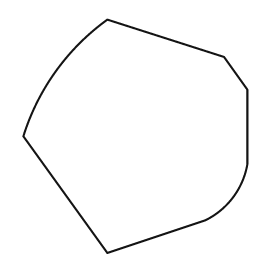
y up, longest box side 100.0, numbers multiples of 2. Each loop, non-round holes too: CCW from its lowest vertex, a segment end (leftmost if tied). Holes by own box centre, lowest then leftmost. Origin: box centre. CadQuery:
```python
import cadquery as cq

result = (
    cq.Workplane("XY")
    .moveTo(-12.0, -50.0)
    .lineTo(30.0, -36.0)
    .threePointArc((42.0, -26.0), (48.0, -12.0))
    .lineTo(48.0, 20.0)
    .lineTo(38.0, 34.0)
    .lineTo(-12.0, 50.0)
    .threePointArc((-34.0, 28.0), (-48.0, 0.0))
    .close()
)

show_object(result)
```